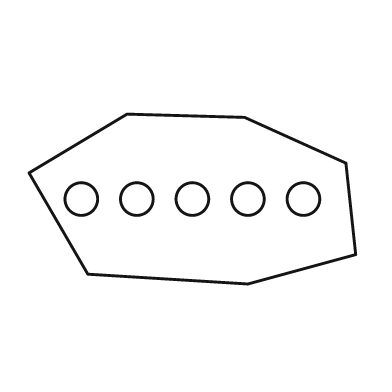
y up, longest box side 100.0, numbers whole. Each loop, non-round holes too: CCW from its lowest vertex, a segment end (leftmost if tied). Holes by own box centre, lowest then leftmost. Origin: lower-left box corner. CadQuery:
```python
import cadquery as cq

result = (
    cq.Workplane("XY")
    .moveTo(67.0, 0.0)
    .lineTo(100.0, 9.0)
    .lineTo(97.0, 37.0)
    .lineTo(66.0, 51.0)
    .lineTo(30.0, 52.0)
    .lineTo(0.0, 34.0)
    .lineTo(18.0, 3.0)
    .close()
    .moveTo(16.0, 26.0)
    .circle(5.0)
    .moveTo(33.0, 26.0)
    .circle(5.0)
    .moveTo(50.0, 26.0)
    .circle(5.0)
    .moveTo(67.0, 26.0)
    .circle(5.0)
    .moveTo(84.0, 26.0)
    .circle(5.0)
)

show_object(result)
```